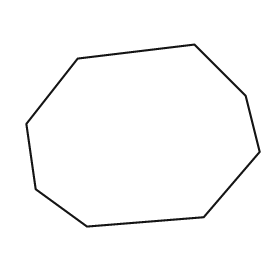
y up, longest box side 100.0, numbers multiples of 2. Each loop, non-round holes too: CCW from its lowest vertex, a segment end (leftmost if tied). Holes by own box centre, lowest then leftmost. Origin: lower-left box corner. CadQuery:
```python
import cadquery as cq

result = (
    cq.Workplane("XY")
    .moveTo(26.0, 0.0)
    .lineTo(76.0, 4.0)
    .lineTo(100.0, 32.0)
    .lineTo(94.0, 56.0)
    .lineTo(72.0, 78.0)
    .lineTo(22.0, 72.0)
    .lineTo(0.0, 44.0)
    .lineTo(4.0, 16.0)
    .close()
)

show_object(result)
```